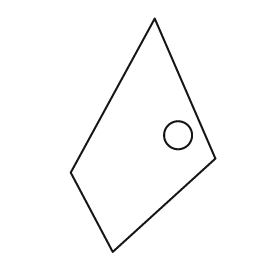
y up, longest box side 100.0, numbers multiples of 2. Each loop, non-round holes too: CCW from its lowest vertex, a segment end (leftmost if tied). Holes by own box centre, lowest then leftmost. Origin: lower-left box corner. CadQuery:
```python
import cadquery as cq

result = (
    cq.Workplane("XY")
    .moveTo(18.0, 0.0)
    .lineTo(62.0, 40.0)
    .lineTo(36.0, 100.0)
    .lineTo(0.0, 34.0)
    .close()
    .moveTo(46.0, 50.0)
    .circle(6.0)
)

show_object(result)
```